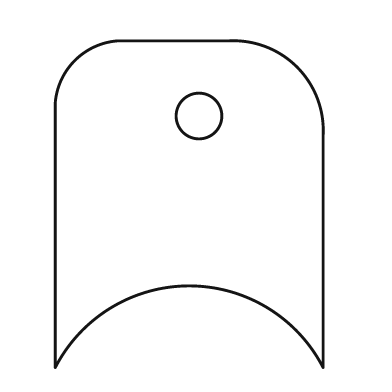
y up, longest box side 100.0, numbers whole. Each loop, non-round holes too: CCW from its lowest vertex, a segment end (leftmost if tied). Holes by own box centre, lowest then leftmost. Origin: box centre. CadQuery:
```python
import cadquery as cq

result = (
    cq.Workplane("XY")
    .moveTo(-41.0, -50.0)
    .threePointArc((0.0, -25.0), (41.0, -50.0))
    .lineTo(41.0, 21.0)
    .threePointArc((33.0, 42.0), (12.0, 50.0))
    .lineTo(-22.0, 50.0)
    .threePointArc((-35.0, 44.0), (-41.0, 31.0))
    .close()
    .moveTo(3.0, 27.0)
    .circle(7.0)
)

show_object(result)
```